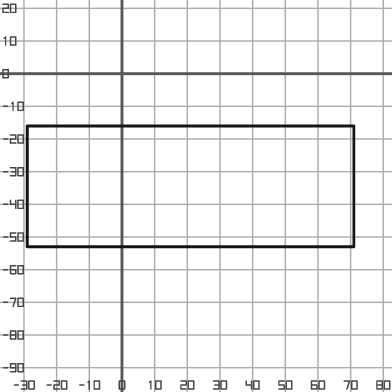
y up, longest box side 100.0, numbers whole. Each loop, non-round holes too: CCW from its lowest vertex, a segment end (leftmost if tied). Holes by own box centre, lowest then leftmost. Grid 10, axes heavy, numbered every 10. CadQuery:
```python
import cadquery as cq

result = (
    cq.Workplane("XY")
    .moveTo(-29.0, -53.0)
    .lineTo(71.0, -53.0)
    .lineTo(71.0, -16.0)
    .lineTo(-29.0, -16.0)
    .close()
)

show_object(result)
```